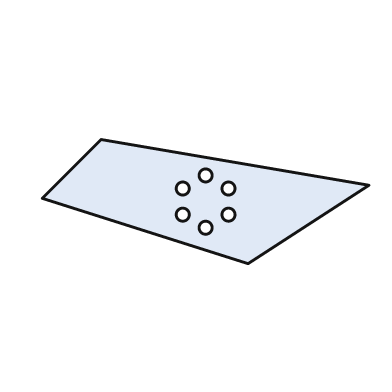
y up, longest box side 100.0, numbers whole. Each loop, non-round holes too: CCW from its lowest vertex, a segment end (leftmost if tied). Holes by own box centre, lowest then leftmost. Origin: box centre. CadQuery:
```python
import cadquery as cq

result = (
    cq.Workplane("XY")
    .moveTo(13.0, -19.0)
    .lineTo(50.0, 5.0)
    .lineTo(-32.0, 19.0)
    .lineTo(-50.0, 1.0)
    .close()
    .moveTo(0.0, -8.0)
    .circle(2.0)
    .moveTo(-7.0, -4.0)
    .circle(2.0)
    .moveTo(7.0, -4.0)
    .circle(2.0)
    .moveTo(-7.0, 4.0)
    .circle(2.0)
    .moveTo(7.0, 4.0)
    .circle(2.0)
    .moveTo(0.0, 8.0)
    .circle(2.0)
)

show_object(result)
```